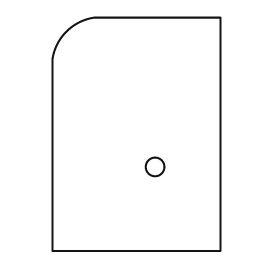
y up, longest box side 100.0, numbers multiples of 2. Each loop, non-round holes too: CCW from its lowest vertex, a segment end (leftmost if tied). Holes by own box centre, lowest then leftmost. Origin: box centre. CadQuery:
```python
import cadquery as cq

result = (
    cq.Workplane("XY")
    .moveTo(-36.0, -50.0)
    .lineTo(36.0, -50.0)
    .lineTo(36.0, 50.0)
    .lineTo(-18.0, 50.0)
    .threePointArc((-30.0, 44.0), (-36.0, 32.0))
    .close()
    .moveTo(8.0, -14.0)
    .circle(4.0)
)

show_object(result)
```